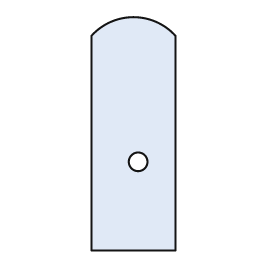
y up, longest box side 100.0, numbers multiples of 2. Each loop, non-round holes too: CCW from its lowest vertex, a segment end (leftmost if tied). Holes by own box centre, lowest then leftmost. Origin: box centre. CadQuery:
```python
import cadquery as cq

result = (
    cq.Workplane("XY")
    .moveTo(-18.0, -50.0)
    .lineTo(18.0, -50.0)
    .lineTo(18.0, 42.0)
    .threePointArc((0.0, 50.0), (-18.0, 42.0))
    .close()
    .moveTo(2.0, -12.0)
    .circle(4.0)
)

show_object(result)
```